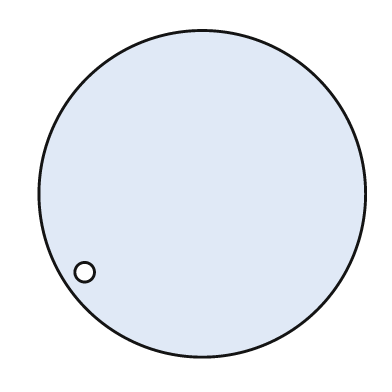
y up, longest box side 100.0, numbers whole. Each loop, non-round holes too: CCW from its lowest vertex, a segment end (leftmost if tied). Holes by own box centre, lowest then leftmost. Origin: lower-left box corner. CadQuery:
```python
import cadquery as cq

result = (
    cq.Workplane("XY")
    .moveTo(50.0, 50.0)
    .circle(50.0)
    .moveTo(14.0, 26.0)
    .circle(3.0)
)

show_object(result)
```